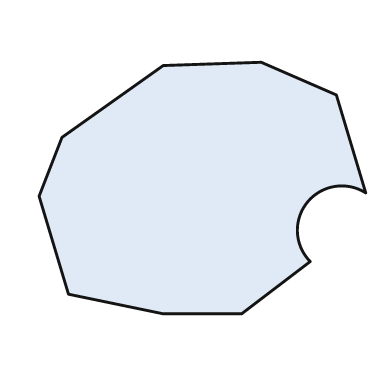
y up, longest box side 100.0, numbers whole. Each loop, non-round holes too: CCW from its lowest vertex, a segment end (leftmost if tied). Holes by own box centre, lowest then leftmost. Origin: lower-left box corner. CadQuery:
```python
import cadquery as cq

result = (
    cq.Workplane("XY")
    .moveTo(38.0, 0.0)
    .lineTo(62.0, 0.0)
    .lineTo(83.0, 16.0)
    .threePointArc((82.0, 34.0), (100.0, 37.0))
    .lineTo(91.0, 67.0)
    .lineTo(68.0, 77.0)
    .lineTo(38.0, 76.0)
    .lineTo(7.0, 54.0)
    .lineTo(0.0, 36.0)
    .lineTo(9.0, 6.0)
    .close()
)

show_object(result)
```